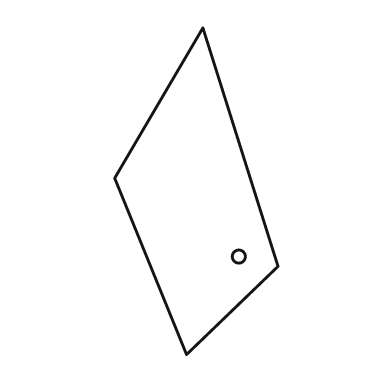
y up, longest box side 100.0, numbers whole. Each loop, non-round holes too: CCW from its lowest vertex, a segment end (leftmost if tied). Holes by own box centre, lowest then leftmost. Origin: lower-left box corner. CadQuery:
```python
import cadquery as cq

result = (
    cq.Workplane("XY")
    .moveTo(22.0, 0.0)
    .lineTo(50.0, 27.0)
    .lineTo(27.0, 100.0)
    .lineTo(0.0, 54.0)
    .close()
    .moveTo(38.0, 30.0)
    .circle(2.0)
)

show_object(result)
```